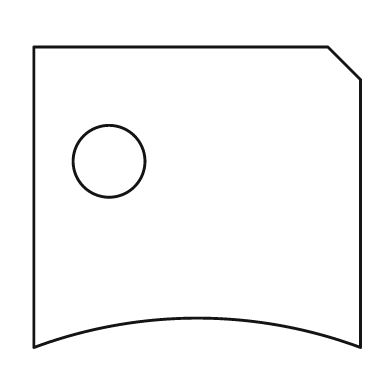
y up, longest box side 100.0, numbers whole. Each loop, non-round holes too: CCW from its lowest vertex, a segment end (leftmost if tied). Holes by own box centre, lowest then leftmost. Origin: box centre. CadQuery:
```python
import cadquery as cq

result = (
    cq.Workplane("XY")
    .moveTo(-50.0, -46.0)
    .threePointArc((0.0, -37.0), (50.0, -46.0))
    .lineTo(50.0, 36.0)
    .lineTo(40.0, 46.0)
    .lineTo(-50.0, 46.0)
    .close()
    .moveTo(-27.0, 11.0)
    .circle(11.0)
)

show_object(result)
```